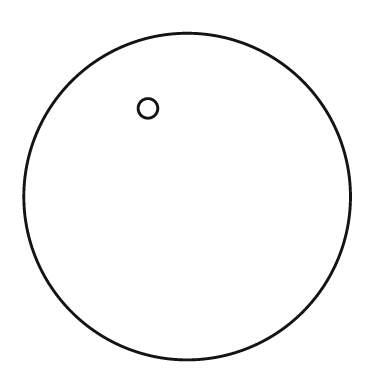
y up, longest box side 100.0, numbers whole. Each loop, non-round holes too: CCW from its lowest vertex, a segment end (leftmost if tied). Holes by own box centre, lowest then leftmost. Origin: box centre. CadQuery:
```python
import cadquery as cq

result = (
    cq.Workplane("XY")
    .moveTo(0.0, 0.0)
    .circle(50.0)
    .moveTo(-12.0, 27.0)
    .circle(3.0)
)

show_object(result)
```